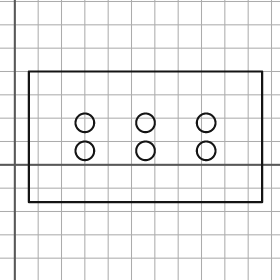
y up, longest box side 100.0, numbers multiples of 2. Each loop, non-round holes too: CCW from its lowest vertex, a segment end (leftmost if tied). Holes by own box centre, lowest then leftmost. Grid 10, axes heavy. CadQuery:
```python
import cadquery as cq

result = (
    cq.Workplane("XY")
    .moveTo(6.0, -16.0)
    .lineTo(106.0, -16.0)
    .lineTo(106.0, 40.0)
    .lineTo(6.0, 40.0)
    .close()
    .moveTo(30.0, 6.0)
    .circle(4.0)
    .moveTo(56.0, 6.0)
    .circle(4.0)
    .moveTo(82.0, 6.0)
    .circle(4.0)
    .moveTo(30.0, 18.0)
    .circle(4.0)
    .moveTo(56.0, 18.0)
    .circle(4.0)
    .moveTo(82.0, 18.0)
    .circle(4.0)
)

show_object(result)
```